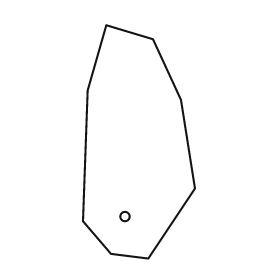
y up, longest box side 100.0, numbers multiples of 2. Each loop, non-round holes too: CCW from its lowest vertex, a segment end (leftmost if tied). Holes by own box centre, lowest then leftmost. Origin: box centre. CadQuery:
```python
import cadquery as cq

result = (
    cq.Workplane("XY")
    .moveTo(4.0, -50.0)
    .lineTo(24.0, -20.0)
    .lineTo(18.0, 18.0)
    .lineTo(6.0, 44.0)
    .lineTo(-14.0, 50.0)
    .lineTo(-22.0, 22.0)
    .lineTo(-24.0, -34.0)
    .lineTo(-12.0, -48.0)
    .close()
    .moveTo(-6.0, -32.0)
    .circle(2.0)
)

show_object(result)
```